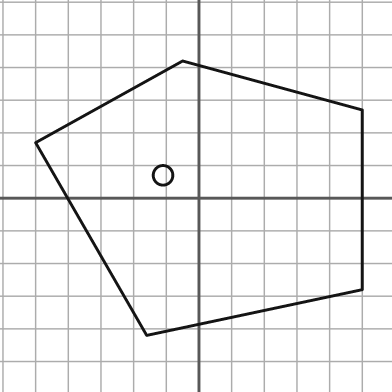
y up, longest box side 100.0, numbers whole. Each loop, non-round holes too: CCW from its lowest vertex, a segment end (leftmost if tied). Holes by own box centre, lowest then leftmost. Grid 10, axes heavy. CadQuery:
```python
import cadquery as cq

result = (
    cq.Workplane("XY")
    .moveTo(-16.0, -42.0)
    .lineTo(50.0, -28.0)
    .lineTo(50.0, 27.0)
    .lineTo(-5.0, 42.0)
    .lineTo(-50.0, 17.0)
    .close()
    .moveTo(-11.0, 7.0)
    .circle(3.0)
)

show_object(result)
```